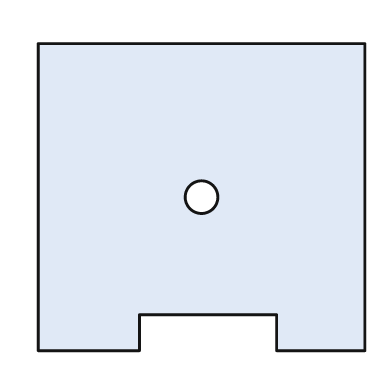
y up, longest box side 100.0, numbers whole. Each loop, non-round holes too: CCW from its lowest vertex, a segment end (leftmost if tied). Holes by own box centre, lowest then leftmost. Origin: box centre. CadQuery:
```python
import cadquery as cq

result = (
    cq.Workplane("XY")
    .moveTo(-50.0, -47.0)
    .lineTo(-19.0, -47.0)
    .lineTo(-19.0, -36.0)
    .lineTo(23.0, -36.0)
    .lineTo(23.0, -47.0)
    .lineTo(50.0, -47.0)
    .lineTo(50.0, 47.0)
    .lineTo(-50.0, 47.0)
    .close()
    .moveTo(0.0, 0.0)
    .circle(5.0)
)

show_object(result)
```